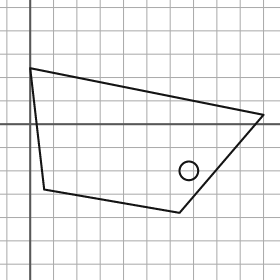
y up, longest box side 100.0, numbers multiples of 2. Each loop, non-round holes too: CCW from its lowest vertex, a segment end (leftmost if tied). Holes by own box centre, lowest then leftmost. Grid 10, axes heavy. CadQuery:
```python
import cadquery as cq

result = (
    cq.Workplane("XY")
    .moveTo(64.0, -38.0)
    .lineTo(100.0, 4.0)
    .lineTo(0.0, 24.0)
    .lineTo(6.0, -28.0)
    .close()
    .moveTo(68.0, -20.0)
    .circle(4.0)
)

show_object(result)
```